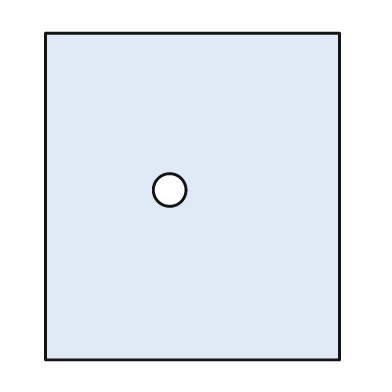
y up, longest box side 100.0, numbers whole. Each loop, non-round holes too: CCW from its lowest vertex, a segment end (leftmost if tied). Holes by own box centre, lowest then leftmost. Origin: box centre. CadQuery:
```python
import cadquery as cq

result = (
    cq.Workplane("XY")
    .moveTo(-45.0, -50.0)
    .lineTo(45.0, -50.0)
    .lineTo(45.0, 50.0)
    .lineTo(-45.0, 50.0)
    .close()
    .moveTo(-7.0, 2.0)
    .circle(5.0)
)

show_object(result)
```